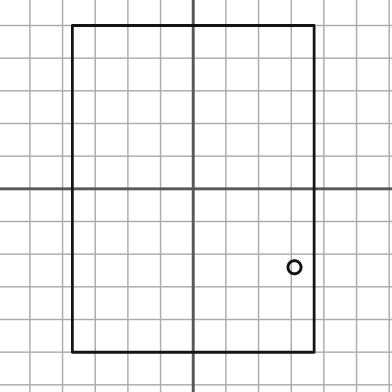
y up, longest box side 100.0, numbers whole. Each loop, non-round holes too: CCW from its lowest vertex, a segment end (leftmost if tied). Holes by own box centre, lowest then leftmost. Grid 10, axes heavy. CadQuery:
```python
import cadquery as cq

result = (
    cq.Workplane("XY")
    .moveTo(-37.0, -50.0)
    .lineTo(37.0, -50.0)
    .lineTo(37.0, 50.0)
    .lineTo(-37.0, 50.0)
    .close()
    .moveTo(31.0, -24.0)
    .circle(2.0)
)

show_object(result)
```